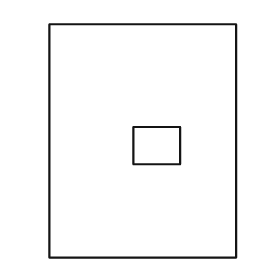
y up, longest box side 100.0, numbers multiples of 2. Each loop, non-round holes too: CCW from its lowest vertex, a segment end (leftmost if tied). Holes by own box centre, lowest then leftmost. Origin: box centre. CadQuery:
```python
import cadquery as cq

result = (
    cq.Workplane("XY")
    .moveTo(-40.0, -50.0)
    .lineTo(40.0, -50.0)
    .lineTo(40.0, 50.0)
    .lineTo(-40.0, 50.0)
    .close()
    .moveTo(-4.0, -10.0)
    .lineTo(16.0, -10.0)
    .lineTo(16.0, 6.0)
    .lineTo(-4.0, 6.0)
    .close()
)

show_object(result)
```